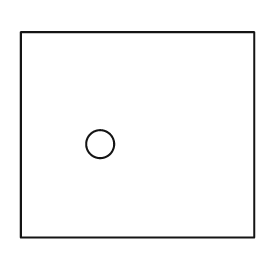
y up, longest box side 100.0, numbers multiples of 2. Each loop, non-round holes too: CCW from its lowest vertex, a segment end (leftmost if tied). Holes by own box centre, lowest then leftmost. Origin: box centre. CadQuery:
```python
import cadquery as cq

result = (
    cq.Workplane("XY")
    .moveTo(-50.0, -44.0)
    .lineTo(50.0, -44.0)
    .lineTo(50.0, 44.0)
    .lineTo(-50.0, 44.0)
    .close()
    .moveTo(-16.0, -4.0)
    .circle(6.0)
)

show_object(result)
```